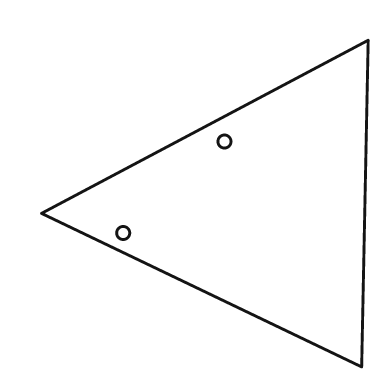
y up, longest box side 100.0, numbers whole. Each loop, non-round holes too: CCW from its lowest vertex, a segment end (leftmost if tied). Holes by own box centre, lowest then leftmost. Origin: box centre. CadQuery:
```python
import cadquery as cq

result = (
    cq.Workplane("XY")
    .moveTo(48.0, -50.0)
    .lineTo(50.0, 50.0)
    .lineTo(-50.0, -3.0)
    .close()
    .moveTo(-25.0, -9.0)
    .circle(2.0)
    .moveTo(6.0, 19.0)
    .circle(2.0)
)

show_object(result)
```